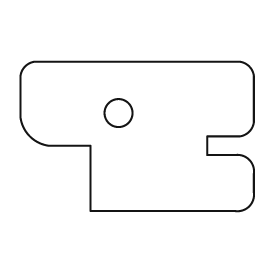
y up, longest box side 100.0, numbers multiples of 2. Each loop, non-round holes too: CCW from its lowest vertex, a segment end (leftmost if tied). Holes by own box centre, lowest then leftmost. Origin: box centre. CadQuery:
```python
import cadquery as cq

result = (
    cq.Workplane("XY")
    .moveTo(-20.0, -32.0)
    .lineTo(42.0, -32.0)
    .threePointArc((48.0, -30.0), (50.0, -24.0))
    .lineTo(50.0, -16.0)
    .threePointArc((48.0, -10.0), (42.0, -8.0))
    .lineTo(30.0, -8.0)
    .lineTo(30.0, 0.0)
    .lineTo(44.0, 0.0)
    .threePointArc((48.0, 2.0), (50.0, 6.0))
    .lineTo(50.0, 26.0)
    .threePointArc((48.0, 30.0), (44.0, 32.0))
    .lineTo(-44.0, 32.0)
    .threePointArc((-48.0, 30.0), (-50.0, 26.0))
    .lineTo(-50.0, 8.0)
    .threePointArc((-46.0, 0.0), (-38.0, -4.0))
    .lineTo(-20.0, -4.0)
    .close()
    .moveTo(-8.0, 10.0)
    .circle(6.0)
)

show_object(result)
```